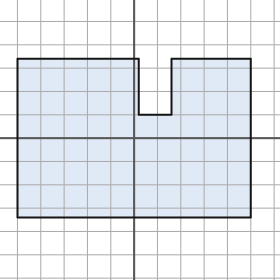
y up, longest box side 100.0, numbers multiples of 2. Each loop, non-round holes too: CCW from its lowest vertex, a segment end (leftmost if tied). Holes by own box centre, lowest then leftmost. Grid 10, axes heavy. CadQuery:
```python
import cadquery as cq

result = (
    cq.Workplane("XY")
    .moveTo(-50.0, -34.0)
    .lineTo(50.0, -34.0)
    .lineTo(50.0, 34.0)
    .lineTo(16.0, 34.0)
    .lineTo(16.0, 10.0)
    .lineTo(2.0, 10.0)
    .lineTo(2.0, 34.0)
    .lineTo(-50.0, 34.0)
    .close()
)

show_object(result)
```